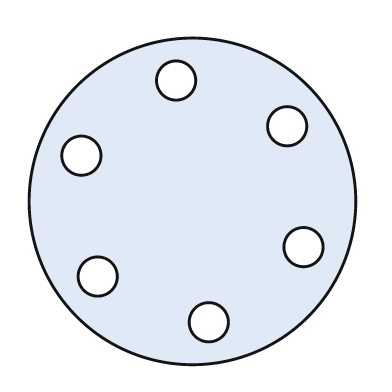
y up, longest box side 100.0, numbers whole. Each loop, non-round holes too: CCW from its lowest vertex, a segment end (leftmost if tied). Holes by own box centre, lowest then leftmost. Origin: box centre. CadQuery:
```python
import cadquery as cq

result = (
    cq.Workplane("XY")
    .moveTo(0.0, 0.0)
    .circle(50.0)
    .moveTo(5.0, -37.0)
    .circle(6.0)
    .moveTo(-29.0, -23.0)
    .circle(6.0)
    .moveTo(34.0, -14.0)
    .circle(6.0)
    .moveTo(-34.0, 14.0)
    .circle(6.0)
    .moveTo(29.0, 23.0)
    .circle(6.0)
    .moveTo(-5.0, 37.0)
    .circle(6.0)
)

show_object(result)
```